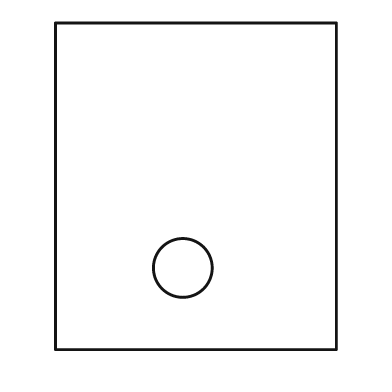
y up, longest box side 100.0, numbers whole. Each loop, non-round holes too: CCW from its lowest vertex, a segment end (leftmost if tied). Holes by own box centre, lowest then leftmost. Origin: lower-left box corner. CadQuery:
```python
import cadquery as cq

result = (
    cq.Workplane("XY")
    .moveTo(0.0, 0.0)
    .lineTo(86.0, 0.0)
    .lineTo(86.0, 100.0)
    .lineTo(0.0, 100.0)
    .close()
    .moveTo(39.0, 25.0)
    .circle(9.0)
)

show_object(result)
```